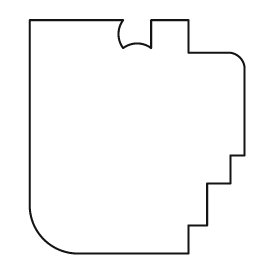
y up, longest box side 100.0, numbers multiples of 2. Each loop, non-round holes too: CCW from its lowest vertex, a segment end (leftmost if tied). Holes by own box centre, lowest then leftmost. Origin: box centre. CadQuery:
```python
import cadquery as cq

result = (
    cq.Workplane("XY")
    .moveTo(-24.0, -50.0)
    .lineTo(22.0, -50.0)
    .lineTo(22.0, -38.0)
    .lineTo(30.0, -38.0)
    .lineTo(30.0, -20.0)
    .lineTo(40.0, -20.0)
    .lineTo(40.0, -8.0)
    .lineTo(46.0, -8.0)
    .lineTo(46.0, 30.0)
    .threePointArc((44.0, 34.0), (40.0, 36.0))
    .lineTo(22.0, 36.0)
    .lineTo(22.0, 50.0)
    .lineTo(6.0, 50.0)
    .lineTo(6.0, 38.0)
    .threePointArc((0.0, 40.0), (-6.0, 38.0))
    .threePointArc((-8.0, 44.0), (-6.0, 50.0))
    .lineTo(-46.0, 50.0)
    .lineTo(-46.0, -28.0)
    .threePointArc((-40.0, -44.0), (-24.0, -50.0))
    .close()
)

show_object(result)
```